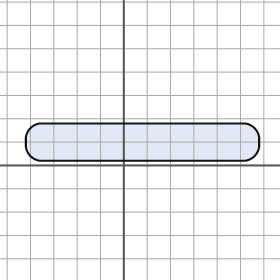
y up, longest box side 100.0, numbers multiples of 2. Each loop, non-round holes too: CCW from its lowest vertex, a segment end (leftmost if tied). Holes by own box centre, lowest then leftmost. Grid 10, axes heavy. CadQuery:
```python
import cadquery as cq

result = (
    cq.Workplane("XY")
    .moveTo(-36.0, 2.0)
    .lineTo(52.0, 2.0)
    .threePointArc((56.0, 4.0), (58.0, 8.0))
    .lineTo(58.0, 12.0)
    .threePointArc((56.0, 16.0), (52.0, 18.0))
    .lineTo(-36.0, 18.0)
    .threePointArc((-40.0, 16.0), (-42.0, 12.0))
    .lineTo(-42.0, 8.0)
    .threePointArc((-40.0, 4.0), (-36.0, 2.0))
    .close()
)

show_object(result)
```